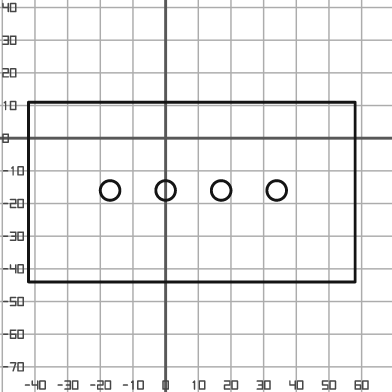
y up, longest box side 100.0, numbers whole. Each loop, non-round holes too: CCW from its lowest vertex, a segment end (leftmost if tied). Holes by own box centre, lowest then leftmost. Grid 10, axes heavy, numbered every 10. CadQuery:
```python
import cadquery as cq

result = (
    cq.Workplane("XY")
    .moveTo(-42.0, -44.0)
    .lineTo(58.0, -44.0)
    .lineTo(58.0, 11.0)
    .lineTo(-42.0, 11.0)
    .close()
    .moveTo(-17.0, -16.0)
    .circle(3.0)
    .moveTo(0.0, -16.0)
    .circle(3.0)
    .moveTo(17.0, -16.0)
    .circle(3.0)
    .moveTo(34.0, -16.0)
    .circle(3.0)
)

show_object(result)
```